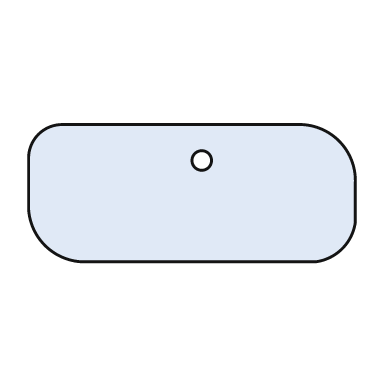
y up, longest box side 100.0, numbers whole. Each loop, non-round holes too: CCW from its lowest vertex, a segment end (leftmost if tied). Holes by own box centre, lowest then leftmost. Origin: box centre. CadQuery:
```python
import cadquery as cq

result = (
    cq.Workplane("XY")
    .moveTo(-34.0, -21.0)
    .lineTo(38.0, -21.0)
    .threePointArc((46.0, -17.0), (50.0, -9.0))
    .lineTo(50.0, 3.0)
    .threePointArc((45.0, 16.0), (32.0, 21.0))
    .lineTo(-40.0, 21.0)
    .threePointArc((-47.0, 18.0), (-50.0, 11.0))
    .lineTo(-50.0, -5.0)
    .threePointArc((-45.0, -16.0), (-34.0, -21.0))
    .close()
    .moveTo(3.0, 10.0)
    .circle(3.0)
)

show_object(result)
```